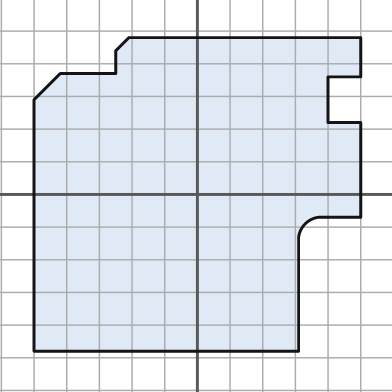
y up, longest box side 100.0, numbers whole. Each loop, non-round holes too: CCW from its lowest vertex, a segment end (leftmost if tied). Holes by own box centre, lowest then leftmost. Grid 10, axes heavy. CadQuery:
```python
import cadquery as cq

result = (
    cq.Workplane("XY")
    .moveTo(-50.0, -48.0)
    .lineTo(31.0, -48.0)
    .lineTo(31.0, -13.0)
    .threePointArc((33.0, -9.0), (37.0, -7.0))
    .lineTo(50.0, -7.0)
    .lineTo(50.0, 22.0)
    .lineTo(40.0, 22.0)
    .lineTo(40.0, 36.0)
    .lineTo(50.0, 36.0)
    .lineTo(50.0, 48.0)
    .lineTo(-21.0, 48.0)
    .lineTo(-25.0, 44.0)
    .lineTo(-25.0, 37.0)
    .lineTo(-42.0, 37.0)
    .lineTo(-50.0, 29.0)
    .close()
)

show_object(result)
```